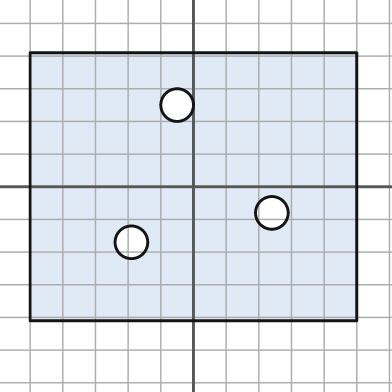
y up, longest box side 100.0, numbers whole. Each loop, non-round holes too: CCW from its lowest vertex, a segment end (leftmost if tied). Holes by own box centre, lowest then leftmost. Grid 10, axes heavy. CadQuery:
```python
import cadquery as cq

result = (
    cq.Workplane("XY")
    .moveTo(-50.0, -41.0)
    .lineTo(50.0, -41.0)
    .lineTo(50.0, 41.0)
    .lineTo(-50.0, 41.0)
    .close()
    .moveTo(-19.0, -17.0)
    .circle(5.0)
    .moveTo(24.0, -8.0)
    .circle(5.0)
    .moveTo(-5.0, 25.0)
    .circle(5.0)
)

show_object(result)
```